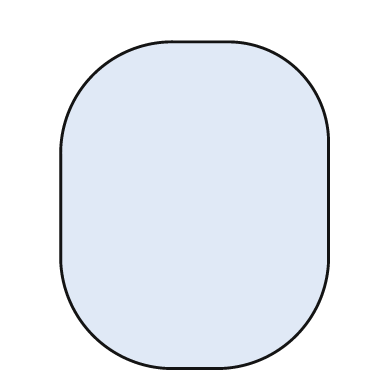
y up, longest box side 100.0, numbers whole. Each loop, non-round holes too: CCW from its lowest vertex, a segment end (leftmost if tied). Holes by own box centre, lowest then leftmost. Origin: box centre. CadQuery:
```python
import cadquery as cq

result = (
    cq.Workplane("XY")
    .moveTo(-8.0, -50.0)
    .lineTo(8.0, -50.0)
    .threePointArc((31.0, -40.0), (41.0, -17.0))
    .lineTo(41.0, 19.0)
    .threePointArc((32.0, 41.0), (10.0, 50.0))
    .lineTo(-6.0, 50.0)
    .threePointArc((-31.0, 40.0), (-41.0, 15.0))
    .lineTo(-41.0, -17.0)
    .threePointArc((-31.0, -40.0), (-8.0, -50.0))
    .close()
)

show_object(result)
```